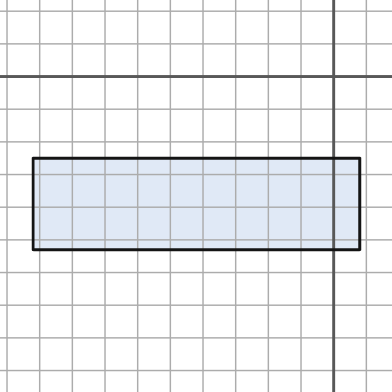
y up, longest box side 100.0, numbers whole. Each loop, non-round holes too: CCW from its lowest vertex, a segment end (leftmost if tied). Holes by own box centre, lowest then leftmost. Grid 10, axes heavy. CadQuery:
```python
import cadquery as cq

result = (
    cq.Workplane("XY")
    .moveTo(-92.0, -53.0)
    .lineTo(8.0, -53.0)
    .lineTo(8.0, -25.0)
    .lineTo(-92.0, -25.0)
    .close()
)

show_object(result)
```